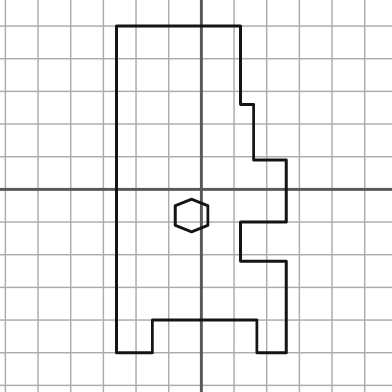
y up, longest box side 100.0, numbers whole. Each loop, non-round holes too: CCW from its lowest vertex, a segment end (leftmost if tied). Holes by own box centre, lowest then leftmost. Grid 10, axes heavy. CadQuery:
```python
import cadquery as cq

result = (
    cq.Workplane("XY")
    .moveTo(-26.0, -50.0)
    .lineTo(-15.0, -50.0)
    .lineTo(-15.0, -40.0)
    .lineTo(17.0, -40.0)
    .lineTo(17.0, -50.0)
    .lineTo(26.0, -50.0)
    .lineTo(26.0, -22.0)
    .lineTo(12.0, -22.0)
    .lineTo(12.0, -10.0)
    .lineTo(26.0, -10.0)
    .lineTo(26.0, 9.0)
    .lineTo(16.0, 9.0)
    .lineTo(16.0, 26.0)
    .lineTo(12.0, 26.0)
    .lineTo(12.0, 50.0)
    .lineTo(-26.0, 50.0)
    .close()
    .moveTo(-3.0, -13.0)
    .lineTo(2.0, -11.0)
    .lineTo(2.0, -5.0)
    .lineTo(-3.0, -3.0)
    .lineTo(-8.0, -5.0)
    .lineTo(-8.0, -11.0)
    .close()
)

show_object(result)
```